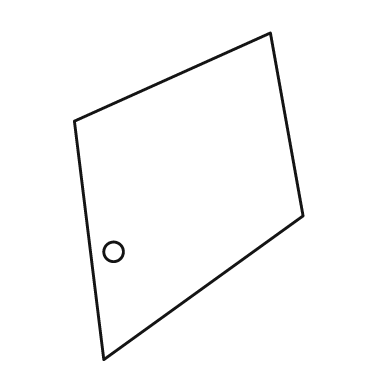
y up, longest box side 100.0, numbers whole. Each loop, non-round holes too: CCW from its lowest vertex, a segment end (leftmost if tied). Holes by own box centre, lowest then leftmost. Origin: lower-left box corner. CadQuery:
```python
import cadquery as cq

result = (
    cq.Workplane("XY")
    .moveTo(9.0, 0.0)
    .lineTo(70.0, 44.0)
    .lineTo(60.0, 100.0)
    .lineTo(0.0, 73.0)
    .close()
    .moveTo(12.0, 33.0)
    .circle(3.0)
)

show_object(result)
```